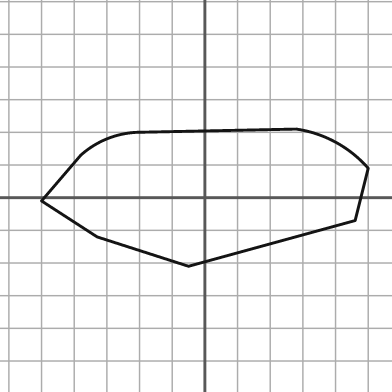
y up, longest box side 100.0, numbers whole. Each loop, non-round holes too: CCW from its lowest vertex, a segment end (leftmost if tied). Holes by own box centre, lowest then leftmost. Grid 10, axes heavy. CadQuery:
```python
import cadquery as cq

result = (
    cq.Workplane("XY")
    .moveTo(-5.0, -21.0)
    .lineTo(46.0, -7.0)
    .lineTo(50.0, 9.0)
    .threePointArc((40.0, 17.0), (28.0, 21.0))
    .lineTo(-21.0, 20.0)
    .threePointArc((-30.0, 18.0), (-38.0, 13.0))
    .lineTo(-50.0, -1.0)
    .lineTo(-33.0, -12.0)
    .close()
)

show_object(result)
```